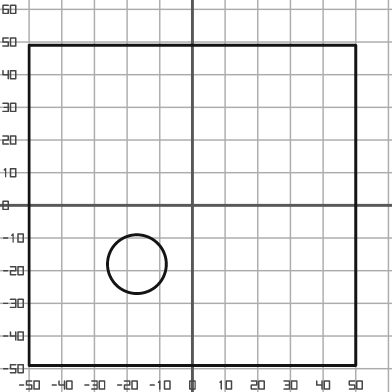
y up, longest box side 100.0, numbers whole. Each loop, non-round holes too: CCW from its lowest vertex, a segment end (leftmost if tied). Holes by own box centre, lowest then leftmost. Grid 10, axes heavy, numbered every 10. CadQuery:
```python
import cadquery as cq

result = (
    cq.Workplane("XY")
    .moveTo(-50.0, -49.0)
    .lineTo(50.0, -49.0)
    .lineTo(50.0, 49.0)
    .lineTo(-50.0, 49.0)
    .close()
    .moveTo(-17.0, -18.0)
    .circle(9.0)
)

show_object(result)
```